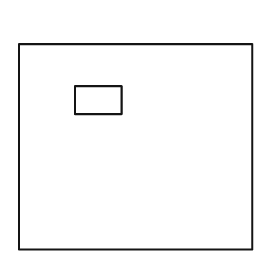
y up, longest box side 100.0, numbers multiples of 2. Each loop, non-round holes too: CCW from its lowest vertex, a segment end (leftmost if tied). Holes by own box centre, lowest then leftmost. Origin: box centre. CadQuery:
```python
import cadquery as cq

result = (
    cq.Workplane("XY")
    .moveTo(-50.0, -44.0)
    .lineTo(50.0, -44.0)
    .lineTo(50.0, 44.0)
    .lineTo(-50.0, 44.0)
    .close()
    .moveTo(-26.0, 14.0)
    .lineTo(-6.0, 14.0)
    .lineTo(-6.0, 26.0)
    .lineTo(-26.0, 26.0)
    .close()
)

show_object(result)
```